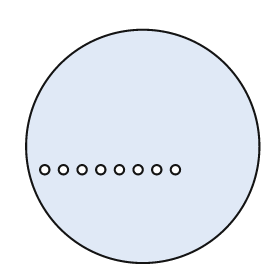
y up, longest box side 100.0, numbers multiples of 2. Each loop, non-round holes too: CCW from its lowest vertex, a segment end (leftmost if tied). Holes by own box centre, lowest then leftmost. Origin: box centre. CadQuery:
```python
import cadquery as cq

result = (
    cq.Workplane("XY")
    .moveTo(0.0, 0.0)
    .circle(50.0)
    .moveTo(-42.0, -10.0)
    .circle(2.0)
    .moveTo(-34.0, -10.0)
    .circle(2.0)
    .moveTo(-26.0, -10.0)
    .circle(2.0)
    .moveTo(-18.0, -10.0)
    .circle(2.0)
    .moveTo(-10.0, -10.0)
    .circle(2.0)
    .moveTo(-2.0, -10.0)
    .circle(2.0)
    .moveTo(6.0, -10.0)
    .circle(2.0)
    .moveTo(14.0, -10.0)
    .circle(2.0)
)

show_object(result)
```